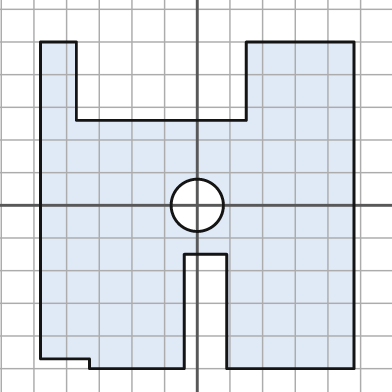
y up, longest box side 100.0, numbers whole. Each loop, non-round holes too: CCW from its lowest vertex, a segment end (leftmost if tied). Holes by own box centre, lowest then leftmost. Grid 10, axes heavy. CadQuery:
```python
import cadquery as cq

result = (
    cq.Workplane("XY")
    .moveTo(-33.0, -50.0)
    .lineTo(-4.0, -50.0)
    .lineTo(-4.0, -15.0)
    .lineTo(9.0, -15.0)
    .lineTo(9.0, -50.0)
    .lineTo(48.0, -50.0)
    .lineTo(48.0, 50.0)
    .lineTo(15.0, 50.0)
    .lineTo(15.0, 26.0)
    .lineTo(-37.0, 26.0)
    .lineTo(-37.0, 50.0)
    .lineTo(-48.0, 50.0)
    .lineTo(-48.0, -47.0)
    .lineTo(-33.0, -47.0)
    .close()
    .moveTo(0.0, 0.0)
    .circle(8.0)
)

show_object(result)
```